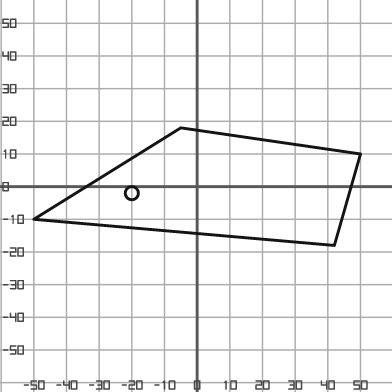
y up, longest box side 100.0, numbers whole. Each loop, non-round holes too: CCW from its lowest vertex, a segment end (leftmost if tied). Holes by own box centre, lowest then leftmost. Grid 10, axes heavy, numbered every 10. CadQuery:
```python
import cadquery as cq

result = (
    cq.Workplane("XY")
    .moveTo(42.0, -18.0)
    .lineTo(50.0, 10.0)
    .lineTo(-5.0, 18.0)
    .lineTo(-50.0, -10.0)
    .close()
    .moveTo(-20.0, -2.0)
    .circle(2.0)
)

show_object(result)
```